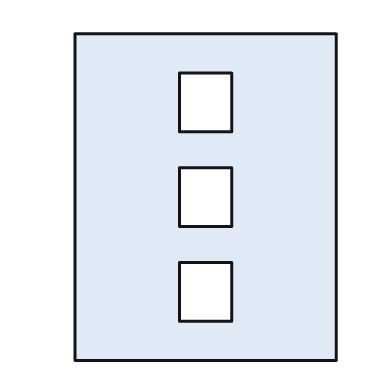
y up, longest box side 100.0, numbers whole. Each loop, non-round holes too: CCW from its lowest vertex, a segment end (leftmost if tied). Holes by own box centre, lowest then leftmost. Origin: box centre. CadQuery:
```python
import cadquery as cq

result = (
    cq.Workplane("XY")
    .moveTo(-40.0, -50.0)
    .lineTo(40.0, -50.0)
    .lineTo(40.0, 50.0)
    .lineTo(-40.0, 50.0)
    .close()
    .moveTo(-8.0, -38.0)
    .lineTo(8.0, -38.0)
    .lineTo(8.0, -20.0)
    .lineTo(-8.0, -20.0)
    .close()
    .moveTo(-8.0, -9.0)
    .lineTo(8.0, -9.0)
    .lineTo(8.0, 9.0)
    .lineTo(-8.0, 9.0)
    .close()
    .moveTo(-8.0, 20.0)
    .lineTo(8.0, 20.0)
    .lineTo(8.0, 38.0)
    .lineTo(-8.0, 38.0)
    .close()
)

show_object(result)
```